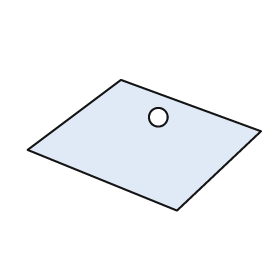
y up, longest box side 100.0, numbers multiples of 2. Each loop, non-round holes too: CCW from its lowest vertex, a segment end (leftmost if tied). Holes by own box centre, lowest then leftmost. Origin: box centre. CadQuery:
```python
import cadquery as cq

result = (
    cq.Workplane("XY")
    .moveTo(14.0, -28.0)
    .lineTo(50.0, 6.0)
    .lineTo(-10.0, 28.0)
    .lineTo(-50.0, -2.0)
    .close()
    .moveTo(6.0, 12.0)
    .circle(4.0)
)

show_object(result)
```